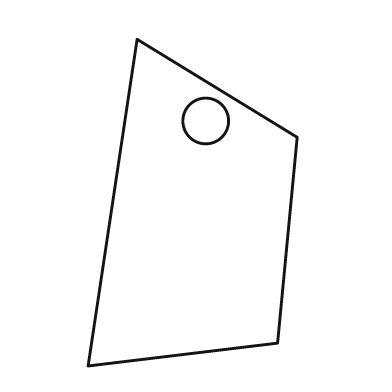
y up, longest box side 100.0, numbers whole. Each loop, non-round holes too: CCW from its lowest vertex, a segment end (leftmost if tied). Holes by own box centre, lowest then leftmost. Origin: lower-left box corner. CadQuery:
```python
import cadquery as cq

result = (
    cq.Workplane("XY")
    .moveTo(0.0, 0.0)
    .lineTo(58.0, 7.0)
    .lineTo(64.0, 70.0)
    .lineTo(15.0, 100.0)
    .close()
    .moveTo(36.0, 75.0)
    .circle(7.0)
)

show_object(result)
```